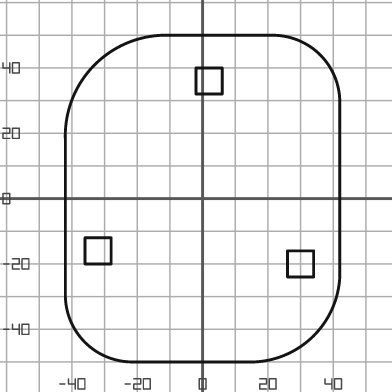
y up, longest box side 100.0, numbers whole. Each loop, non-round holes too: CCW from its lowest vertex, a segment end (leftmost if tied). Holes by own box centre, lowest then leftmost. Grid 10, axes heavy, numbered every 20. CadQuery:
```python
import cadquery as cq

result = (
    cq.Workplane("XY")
    .moveTo(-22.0, -50.0)
    .lineTo(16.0, -50.0)
    .threePointArc((34.0, -42.0), (42.0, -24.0))
    .lineTo(42.0, 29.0)
    .threePointArc((36.0, 44.0), (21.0, 50.0))
    .lineTo(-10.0, 50.0)
    .threePointArc((-33.0, 41.0), (-42.0, 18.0))
    .lineTo(-42.0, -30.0)
    .threePointArc((-36.0, -44.0), (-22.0, -50.0))
    .close()
    .moveTo(26.0, -24.0)
    .lineTo(34.0, -24.0)
    .lineTo(34.0, -16.0)
    .lineTo(26.0, -16.0)
    .close()
    .moveTo(-36.0, -20.0)
    .lineTo(-28.0, -20.0)
    .lineTo(-28.0, -12.0)
    .lineTo(-36.0, -12.0)
    .close()
    .moveTo(-2.0, 32.0)
    .lineTo(6.0, 32.0)
    .lineTo(6.0, 40.0)
    .lineTo(-2.0, 40.0)
    .close()
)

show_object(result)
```